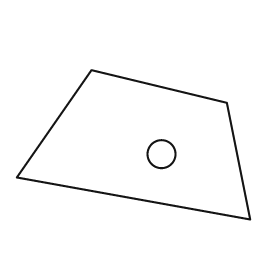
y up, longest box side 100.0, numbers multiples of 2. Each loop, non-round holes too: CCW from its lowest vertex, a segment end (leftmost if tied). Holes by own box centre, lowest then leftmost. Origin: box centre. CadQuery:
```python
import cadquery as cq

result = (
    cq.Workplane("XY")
    .moveTo(50.0, -32.0)
    .lineTo(40.0, 18.0)
    .lineTo(-18.0, 32.0)
    .lineTo(-50.0, -14.0)
    .close()
    .moveTo(12.0, -4.0)
    .circle(6.0)
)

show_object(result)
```